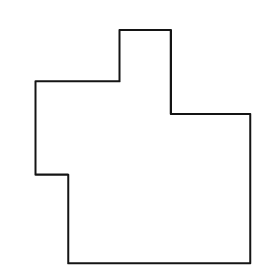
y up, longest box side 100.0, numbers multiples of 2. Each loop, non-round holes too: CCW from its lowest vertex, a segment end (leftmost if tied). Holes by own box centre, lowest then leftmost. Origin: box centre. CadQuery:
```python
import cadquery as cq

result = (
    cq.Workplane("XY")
    .moveTo(-32.0, -50.0)
    .lineTo(46.0, -50.0)
    .lineTo(46.0, 14.0)
    .lineTo(12.0, 14.0)
    .lineTo(12.0, 50.0)
    .lineTo(-10.0, 50.0)
    .lineTo(-10.0, 28.0)
    .lineTo(-46.0, 28.0)
    .lineTo(-46.0, -12.0)
    .lineTo(-32.0, -12.0)
    .close()
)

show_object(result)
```